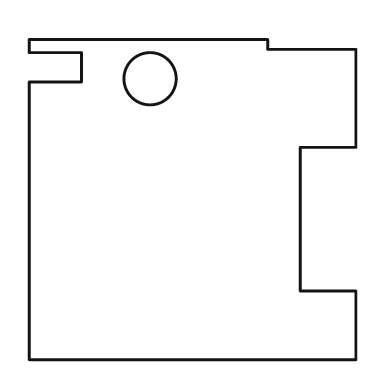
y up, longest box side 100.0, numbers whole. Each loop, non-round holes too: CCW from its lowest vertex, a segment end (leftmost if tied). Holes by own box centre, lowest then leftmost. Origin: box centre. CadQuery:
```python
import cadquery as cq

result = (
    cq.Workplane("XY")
    .moveTo(-50.0, -49.0)
    .lineTo(50.0, -49.0)
    .lineTo(50.0, -28.0)
    .lineTo(33.0, -28.0)
    .lineTo(33.0, 16.0)
    .lineTo(50.0, 16.0)
    .lineTo(50.0, 46.0)
    .lineTo(23.0, 46.0)
    .lineTo(23.0, 49.0)
    .lineTo(-50.0, 49.0)
    .lineTo(-50.0, 45.0)
    .lineTo(-34.0, 45.0)
    .lineTo(-34.0, 36.0)
    .lineTo(-50.0, 36.0)
    .close()
    .moveTo(-13.0, 37.0)
    .circle(8.0)
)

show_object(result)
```